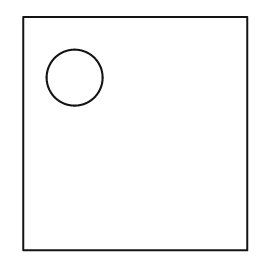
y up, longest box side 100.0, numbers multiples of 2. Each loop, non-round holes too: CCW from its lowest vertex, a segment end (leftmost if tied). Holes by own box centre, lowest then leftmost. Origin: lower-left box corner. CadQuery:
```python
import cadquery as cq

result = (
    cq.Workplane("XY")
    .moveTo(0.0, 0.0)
    .lineTo(96.0, 0.0)
    .lineTo(96.0, 100.0)
    .lineTo(0.0, 100.0)
    .close()
    .moveTo(22.0, 74.0)
    .circle(12.0)
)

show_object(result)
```